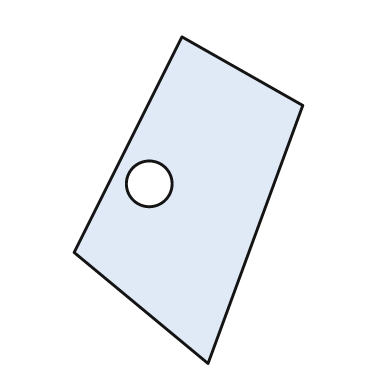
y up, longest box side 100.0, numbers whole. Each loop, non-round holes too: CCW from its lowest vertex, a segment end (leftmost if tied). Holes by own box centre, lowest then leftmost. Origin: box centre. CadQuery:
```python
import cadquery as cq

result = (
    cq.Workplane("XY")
    .moveTo(6.0, -50.0)
    .lineTo(35.0, 29.0)
    .lineTo(-2.0, 50.0)
    .lineTo(-35.0, -16.0)
    .close()
    .moveTo(-12.0, 5.0)
    .circle(7.0)
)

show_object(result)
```